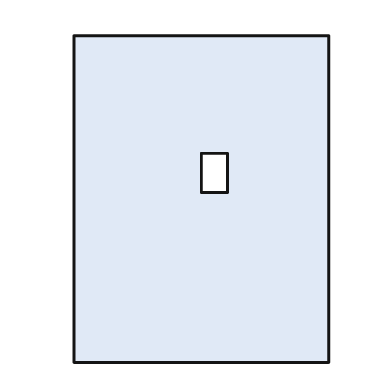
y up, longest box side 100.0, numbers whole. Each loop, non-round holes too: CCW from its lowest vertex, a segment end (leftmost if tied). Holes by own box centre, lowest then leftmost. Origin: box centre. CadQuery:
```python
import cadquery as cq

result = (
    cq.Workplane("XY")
    .moveTo(-39.0, -50.0)
    .lineTo(39.0, -50.0)
    .lineTo(39.0, 50.0)
    .lineTo(-39.0, 50.0)
    .close()
    .moveTo(0.0, 2.0)
    .lineTo(8.0, 2.0)
    .lineTo(8.0, 14.0)
    .lineTo(0.0, 14.0)
    .close()
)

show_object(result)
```